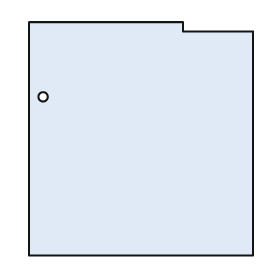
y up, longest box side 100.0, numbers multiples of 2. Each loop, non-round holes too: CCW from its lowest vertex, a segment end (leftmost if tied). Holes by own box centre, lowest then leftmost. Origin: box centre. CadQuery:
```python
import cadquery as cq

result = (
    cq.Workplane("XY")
    .moveTo(-48.0, -50.0)
    .lineTo(48.0, -50.0)
    .lineTo(48.0, 46.0)
    .lineTo(18.0, 46.0)
    .lineTo(18.0, 50.0)
    .lineTo(-48.0, 50.0)
    .close()
    .moveTo(-42.0, 18.0)
    .circle(2.0)
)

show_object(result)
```